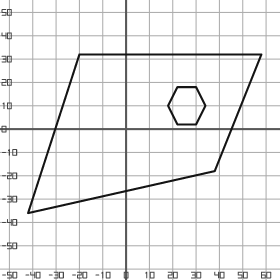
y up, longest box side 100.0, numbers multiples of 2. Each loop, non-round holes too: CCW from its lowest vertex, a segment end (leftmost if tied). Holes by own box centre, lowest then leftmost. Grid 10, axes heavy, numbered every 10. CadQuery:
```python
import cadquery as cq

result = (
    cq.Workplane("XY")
    .moveTo(-42.0, -36.0)
    .lineTo(38.0, -18.0)
    .lineTo(58.0, 32.0)
    .lineTo(-20.0, 32.0)
    .close()
    .moveTo(22.0, 2.0)
    .lineTo(30.0, 2.0)
    .lineTo(34.0, 10.0)
    .lineTo(30.0, 18.0)
    .lineTo(22.0, 18.0)
    .lineTo(18.0, 10.0)
    .close()
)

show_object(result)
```